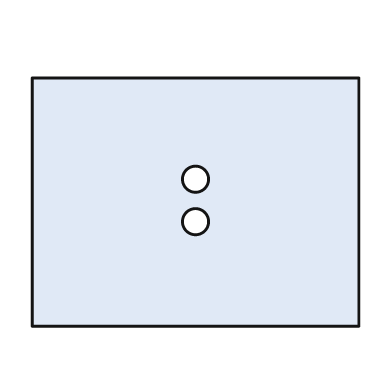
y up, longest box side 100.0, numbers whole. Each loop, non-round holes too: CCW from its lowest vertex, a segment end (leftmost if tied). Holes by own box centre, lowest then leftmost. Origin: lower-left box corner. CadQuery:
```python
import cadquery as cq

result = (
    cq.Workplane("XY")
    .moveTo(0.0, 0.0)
    .lineTo(100.0, 0.0)
    .lineTo(100.0, 76.0)
    .lineTo(0.0, 76.0)
    .close()
    .moveTo(50.0, 32.0)
    .circle(4.0)
    .moveTo(50.0, 45.0)
    .circle(4.0)
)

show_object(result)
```